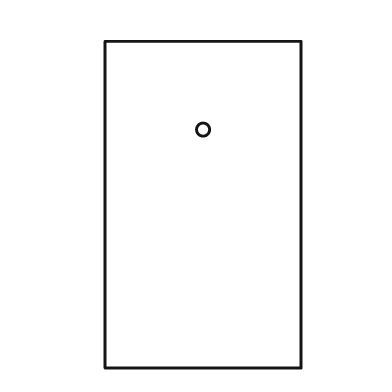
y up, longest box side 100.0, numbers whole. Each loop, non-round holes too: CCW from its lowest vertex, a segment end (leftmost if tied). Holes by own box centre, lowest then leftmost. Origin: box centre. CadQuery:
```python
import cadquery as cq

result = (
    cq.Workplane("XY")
    .moveTo(-30.0, -50.0)
    .lineTo(30.0, -50.0)
    .lineTo(30.0, 50.0)
    .lineTo(-30.0, 50.0)
    .close()
    .moveTo(0.0, 23.0)
    .circle(2.0)
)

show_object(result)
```